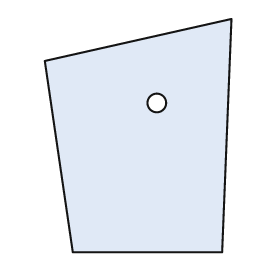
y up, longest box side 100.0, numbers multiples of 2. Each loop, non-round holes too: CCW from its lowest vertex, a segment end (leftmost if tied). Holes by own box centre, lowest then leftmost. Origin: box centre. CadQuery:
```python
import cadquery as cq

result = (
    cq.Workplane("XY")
    .moveTo(-28.0, -50.0)
    .lineTo(36.0, -50.0)
    .lineTo(40.0, 50.0)
    .lineTo(-40.0, 32.0)
    .close()
    .moveTo(8.0, 14.0)
    .circle(4.0)
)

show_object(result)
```